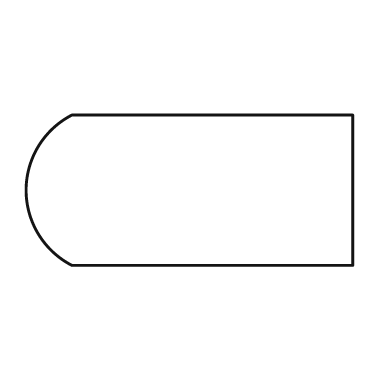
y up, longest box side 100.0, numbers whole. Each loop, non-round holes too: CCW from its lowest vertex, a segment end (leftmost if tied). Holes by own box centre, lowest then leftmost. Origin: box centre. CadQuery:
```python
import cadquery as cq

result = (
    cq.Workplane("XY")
    .moveTo(-36.0, -23.0)
    .lineTo(50.0, -23.0)
    .lineTo(50.0, 23.0)
    .lineTo(-36.0, 23.0)
    .threePointArc((-50.0, 0.0), (-36.0, -23.0))
    .close()
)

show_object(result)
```